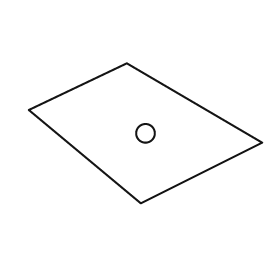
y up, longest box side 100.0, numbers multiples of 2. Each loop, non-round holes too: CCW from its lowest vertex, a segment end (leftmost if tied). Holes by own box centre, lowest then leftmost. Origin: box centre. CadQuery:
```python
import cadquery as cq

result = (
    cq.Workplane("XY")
    .moveTo(-2.0, -30.0)
    .lineTo(50.0, -4.0)
    .lineTo(-8.0, 30.0)
    .lineTo(-50.0, 10.0)
    .close()
    .moveTo(0.0, 0.0)
    .circle(4.0)
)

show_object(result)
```